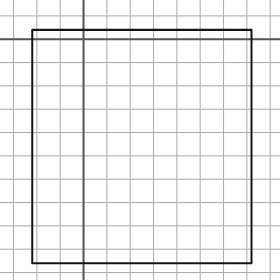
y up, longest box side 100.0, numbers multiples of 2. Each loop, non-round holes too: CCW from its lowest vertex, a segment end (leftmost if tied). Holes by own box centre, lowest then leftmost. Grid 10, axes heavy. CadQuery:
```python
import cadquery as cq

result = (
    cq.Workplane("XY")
    .moveTo(-22.0, -96.0)
    .lineTo(72.0, -96.0)
    .lineTo(72.0, 4.0)
    .lineTo(-22.0, 4.0)
    .close()
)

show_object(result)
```